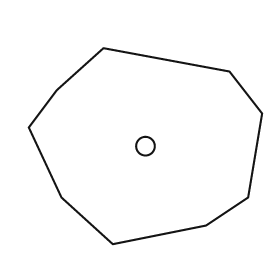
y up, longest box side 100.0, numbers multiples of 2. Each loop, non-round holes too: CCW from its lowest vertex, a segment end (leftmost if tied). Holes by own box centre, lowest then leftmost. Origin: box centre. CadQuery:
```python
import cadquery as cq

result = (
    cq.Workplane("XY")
    .moveTo(-14.0, -42.0)
    .lineTo(26.0, -34.0)
    .lineTo(44.0, -22.0)
    .lineTo(50.0, 14.0)
    .lineTo(36.0, 32.0)
    .lineTo(-18.0, 42.0)
    .lineTo(-38.0, 24.0)
    .lineTo(-50.0, 8.0)
    .lineTo(-36.0, -22.0)
    .close()
    .moveTo(0.0, 0.0)
    .circle(4.0)
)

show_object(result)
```